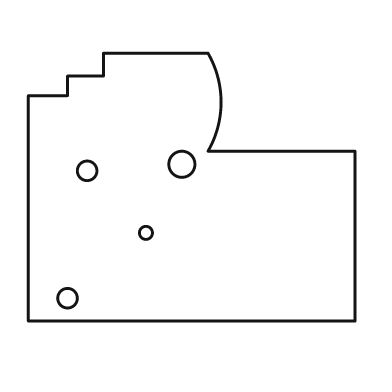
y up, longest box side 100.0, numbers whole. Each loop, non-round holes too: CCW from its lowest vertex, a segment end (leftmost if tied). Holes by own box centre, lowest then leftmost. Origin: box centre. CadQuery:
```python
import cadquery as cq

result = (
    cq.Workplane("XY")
    .moveTo(-50.0, -41.0)
    .lineTo(50.0, -41.0)
    .lineTo(50.0, 11.0)
    .lineTo(5.0, 11.0)
    .threePointArc((9.0, 26.0), (5.0, 41.0))
    .lineTo(-27.0, 41.0)
    .lineTo(-27.0, 34.0)
    .lineTo(-38.0, 34.0)
    .lineTo(-38.0, 28.0)
    .lineTo(-50.0, 28.0)
    .close()
    .moveTo(-38.0, -34.0)
    .circle(3.0)
    .moveTo(-14.0, -14.0)
    .circle(2.0)
    .moveTo(-32.0, 5.0)
    .circle(3.0)
    .moveTo(-3.0, 7.0)
    .circle(4.0)
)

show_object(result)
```